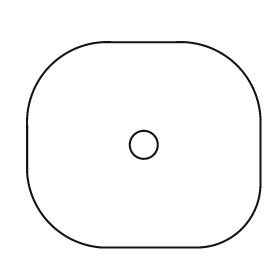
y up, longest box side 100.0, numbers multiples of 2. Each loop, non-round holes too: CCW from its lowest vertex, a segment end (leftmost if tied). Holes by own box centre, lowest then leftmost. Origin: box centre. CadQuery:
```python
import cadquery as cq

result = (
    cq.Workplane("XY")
    .moveTo(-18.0, -44.0)
    .lineTo(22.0, -44.0)
    .threePointArc((42.0, -36.0), (50.0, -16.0))
    .lineTo(50.0, 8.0)
    .threePointArc((40.0, 34.0), (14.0, 44.0))
    .lineTo(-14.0, 44.0)
    .threePointArc((-40.0, 34.0), (-50.0, 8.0))
    .lineTo(-50.0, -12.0)
    .threePointArc((-40.0, -34.0), (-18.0, -44.0))
    .close()
    .moveTo(0.0, 0.0)
    .circle(6.0)
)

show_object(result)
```